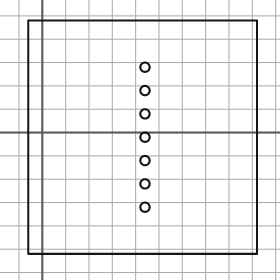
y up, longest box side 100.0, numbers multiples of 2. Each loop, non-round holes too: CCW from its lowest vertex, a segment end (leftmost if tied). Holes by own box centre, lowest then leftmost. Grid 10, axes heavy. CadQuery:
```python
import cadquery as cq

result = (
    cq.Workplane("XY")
    .moveTo(-6.0, -52.0)
    .lineTo(92.0, -52.0)
    .lineTo(92.0, 48.0)
    .lineTo(-6.0, 48.0)
    .close()
    .moveTo(44.0, -32.0)
    .circle(2.0)
    .moveTo(44.0, -22.0)
    .circle(2.0)
    .moveTo(44.0, -12.0)
    .circle(2.0)
    .moveTo(44.0, -2.0)
    .circle(2.0)
    .moveTo(44.0, 8.0)
    .circle(2.0)
    .moveTo(44.0, 18.0)
    .circle(2.0)
    .moveTo(44.0, 28.0)
    .circle(2.0)
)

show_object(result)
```